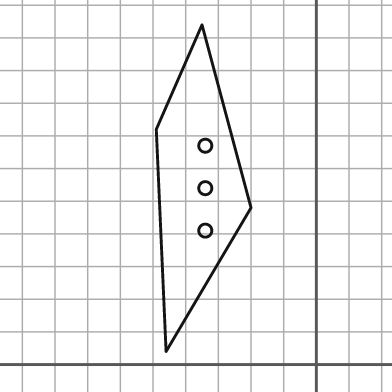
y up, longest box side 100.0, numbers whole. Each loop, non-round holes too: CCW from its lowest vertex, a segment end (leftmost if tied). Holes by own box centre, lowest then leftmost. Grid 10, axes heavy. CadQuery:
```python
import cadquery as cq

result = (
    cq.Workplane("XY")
    .moveTo(-46.0, 4.0)
    .lineTo(-20.0, 48.0)
    .lineTo(-35.0, 104.0)
    .lineTo(-49.0, 72.0)
    .close()
    .moveTo(-34.0, 41.0)
    .circle(2.0)
    .moveTo(-34.0, 54.0)
    .circle(2.0)
    .moveTo(-34.0, 67.0)
    .circle(2.0)
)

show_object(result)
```